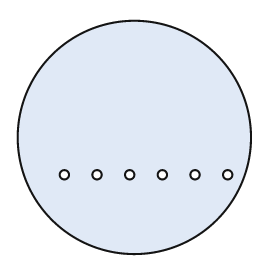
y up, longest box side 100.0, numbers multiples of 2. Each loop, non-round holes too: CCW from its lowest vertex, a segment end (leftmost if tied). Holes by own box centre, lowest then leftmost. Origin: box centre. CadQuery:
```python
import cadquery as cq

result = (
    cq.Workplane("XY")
    .moveTo(0.0, 0.0)
    .circle(50.0)
    .moveTo(-30.0, -16.0)
    .circle(2.0)
    .moveTo(-16.0, -16.0)
    .circle(2.0)
    .moveTo(-2.0, -16.0)
    .circle(2.0)
    .moveTo(12.0, -16.0)
    .circle(2.0)
    .moveTo(26.0, -16.0)
    .circle(2.0)
    .moveTo(40.0, -16.0)
    .circle(2.0)
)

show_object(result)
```